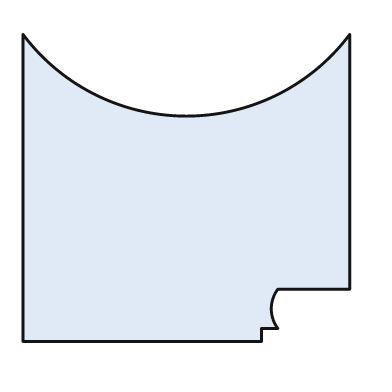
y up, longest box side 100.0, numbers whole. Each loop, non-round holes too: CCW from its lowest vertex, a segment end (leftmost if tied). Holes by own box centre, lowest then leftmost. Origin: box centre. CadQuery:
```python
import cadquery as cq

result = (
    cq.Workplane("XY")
    .moveTo(-50.0, -47.0)
    .lineTo(23.0, -47.0)
    .lineTo(23.0, -43.0)
    .lineTo(28.0, -43.0)
    .threePointArc((26.0, -37.0), (28.0, -31.0))
    .lineTo(50.0, -31.0)
    .lineTo(50.0, 47.0)
    .threePointArc((0.0, 22.0), (-50.0, 47.0))
    .close()
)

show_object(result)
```